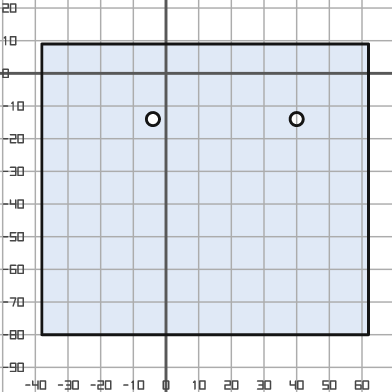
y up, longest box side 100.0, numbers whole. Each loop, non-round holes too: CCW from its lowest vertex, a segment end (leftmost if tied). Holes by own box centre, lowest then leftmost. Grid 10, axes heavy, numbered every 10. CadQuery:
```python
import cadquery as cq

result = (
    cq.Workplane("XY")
    .moveTo(-38.0, -80.0)
    .lineTo(62.0, -80.0)
    .lineTo(62.0, 9.0)
    .lineTo(-38.0, 9.0)
    .close()
    .moveTo(-4.0, -14.0)
    .circle(2.0)
    .moveTo(40.0, -14.0)
    .circle(2.0)
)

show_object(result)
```